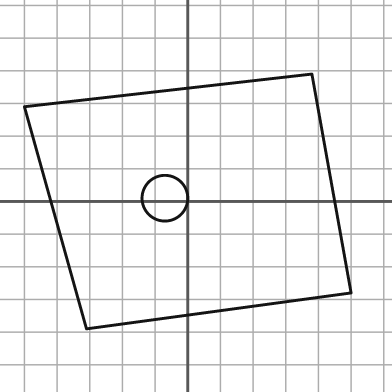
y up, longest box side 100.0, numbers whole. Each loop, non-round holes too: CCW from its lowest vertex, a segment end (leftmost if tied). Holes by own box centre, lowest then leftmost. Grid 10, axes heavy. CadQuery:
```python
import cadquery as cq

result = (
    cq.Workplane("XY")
    .moveTo(-31.0, -39.0)
    .lineTo(50.0, -28.0)
    .lineTo(38.0, 39.0)
    .lineTo(-50.0, 29.0)
    .close()
    .moveTo(-7.0, 1.0)
    .circle(7.0)
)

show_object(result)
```